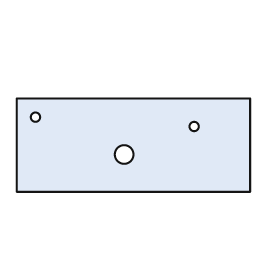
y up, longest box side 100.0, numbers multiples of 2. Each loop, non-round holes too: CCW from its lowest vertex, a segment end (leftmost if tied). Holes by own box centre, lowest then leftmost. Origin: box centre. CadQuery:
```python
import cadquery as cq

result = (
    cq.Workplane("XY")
    .moveTo(-50.0, -20.0)
    .lineTo(50.0, -20.0)
    .lineTo(50.0, 20.0)
    .lineTo(-50.0, 20.0)
    .close()
    .moveTo(-4.0, -4.0)
    .circle(4.0)
    .moveTo(26.0, 8.0)
    .circle(2.0)
    .moveTo(-42.0, 12.0)
    .circle(2.0)
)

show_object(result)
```